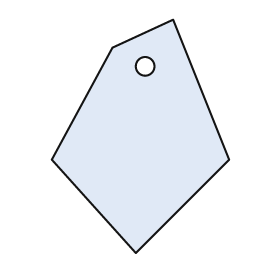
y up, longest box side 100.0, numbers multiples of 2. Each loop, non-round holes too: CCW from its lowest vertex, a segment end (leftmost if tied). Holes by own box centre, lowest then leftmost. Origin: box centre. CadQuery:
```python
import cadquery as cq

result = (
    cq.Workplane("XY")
    .moveTo(-2.0, -50.0)
    .lineTo(38.0, -10.0)
    .lineTo(14.0, 50.0)
    .lineTo(-12.0, 38.0)
    .lineTo(-38.0, -10.0)
    .close()
    .moveTo(2.0, 30.0)
    .circle(4.0)
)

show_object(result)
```